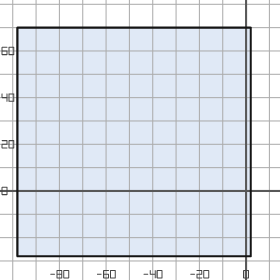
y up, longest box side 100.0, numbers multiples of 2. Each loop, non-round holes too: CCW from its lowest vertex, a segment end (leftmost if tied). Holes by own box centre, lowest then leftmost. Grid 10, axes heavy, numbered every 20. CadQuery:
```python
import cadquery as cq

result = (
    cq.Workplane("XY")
    .moveTo(-98.0, -28.0)
    .lineTo(2.0, -28.0)
    .lineTo(2.0, 70.0)
    .lineTo(-98.0, 70.0)
    .close()
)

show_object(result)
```